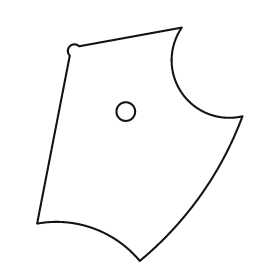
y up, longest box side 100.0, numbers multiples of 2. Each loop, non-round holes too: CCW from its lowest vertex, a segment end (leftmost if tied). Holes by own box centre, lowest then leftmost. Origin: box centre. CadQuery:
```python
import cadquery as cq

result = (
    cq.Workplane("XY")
    .moveTo(0.0, -50.0)
    .threePointArc((26.0, -22.0), (44.0, 12.0))
    .threePointArc((18.0, 22.0), (18.0, 50.0))
    .lineTo(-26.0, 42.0)
    .threePointArc((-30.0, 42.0), (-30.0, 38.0))
    .lineTo(-44.0, -34.0)
    .threePointArc((-20.0, -36.0), (0.0, -50.0))
    .close()
    .moveTo(-6.0, 14.0)
    .circle(4.0)
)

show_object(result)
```